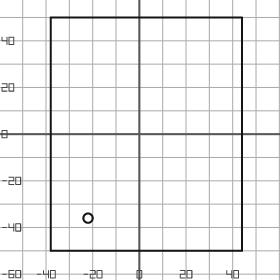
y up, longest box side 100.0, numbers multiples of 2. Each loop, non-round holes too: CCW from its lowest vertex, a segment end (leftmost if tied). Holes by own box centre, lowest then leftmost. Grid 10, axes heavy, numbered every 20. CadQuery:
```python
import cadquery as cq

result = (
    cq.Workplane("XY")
    .moveTo(-38.0, -50.0)
    .lineTo(44.0, -50.0)
    .lineTo(44.0, 50.0)
    .lineTo(-38.0, 50.0)
    .close()
    .moveTo(-22.0, -36.0)
    .circle(2.0)
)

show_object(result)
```